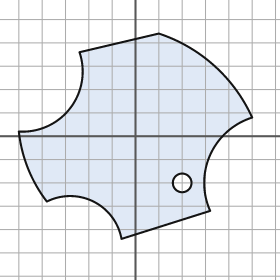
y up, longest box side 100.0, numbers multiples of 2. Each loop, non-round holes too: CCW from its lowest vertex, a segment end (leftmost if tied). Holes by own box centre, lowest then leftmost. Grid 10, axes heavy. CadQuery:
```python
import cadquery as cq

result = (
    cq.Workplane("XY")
    .moveTo(-6.0, -44.0)
    .lineTo(32.0, -32.0)
    .threePointArc((32.0, -8.0), (50.0, 8.0))
    .threePointArc((34.0, 30.0), (10.0, 44.0))
    .lineTo(-24.0, 36.0)
    .threePointArc((-28.0, 12.0), (-50.0, 2.0))
    .threePointArc((-46.0, -14.0), (-38.0, -28.0))
    .threePointArc((-18.0, -28.0), (-6.0, -44.0))
    .close()
    .moveTo(20.0, -20.0)
    .circle(4.0)
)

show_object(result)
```